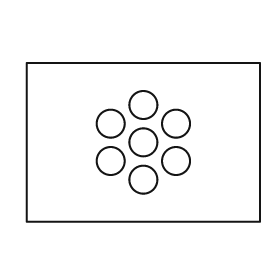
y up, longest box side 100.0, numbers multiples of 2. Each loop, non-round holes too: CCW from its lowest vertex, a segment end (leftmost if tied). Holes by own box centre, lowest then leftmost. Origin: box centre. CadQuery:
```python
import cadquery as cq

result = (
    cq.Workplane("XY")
    .moveTo(-50.0, -34.0)
    .lineTo(50.0, -34.0)
    .lineTo(50.0, 34.0)
    .lineTo(-50.0, 34.0)
    .close()
    .moveTo(0.0, -16.0)
    .circle(6.0)
    .moveTo(-14.0, -8.0)
    .circle(6.0)
    .moveTo(14.0, -8.0)
    .circle(6.0)
    .moveTo(0.0, 0.0)
    .circle(6.0)
    .moveTo(-14.0, 8.0)
    .circle(6.0)
    .moveTo(14.0, 8.0)
    .circle(6.0)
    .moveTo(0.0, 16.0)
    .circle(6.0)
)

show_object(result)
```